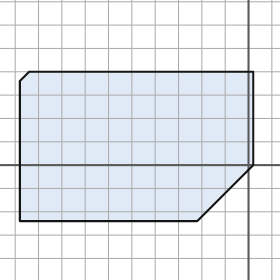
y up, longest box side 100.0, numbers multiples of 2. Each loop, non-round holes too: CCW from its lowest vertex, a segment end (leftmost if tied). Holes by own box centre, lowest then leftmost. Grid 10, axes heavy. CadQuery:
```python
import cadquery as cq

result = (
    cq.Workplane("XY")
    .moveTo(-98.0, -24.0)
    .lineTo(-22.0, -24.0)
    .lineTo(2.0, 0.0)
    .lineTo(2.0, 40.0)
    .lineTo(-94.0, 40.0)
    .lineTo(-98.0, 36.0)
    .close()
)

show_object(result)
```